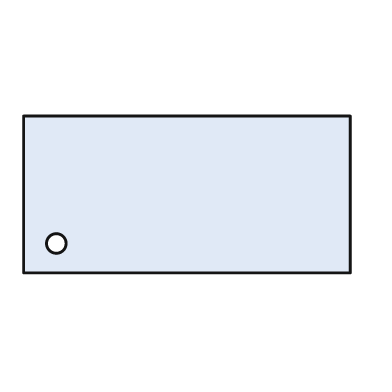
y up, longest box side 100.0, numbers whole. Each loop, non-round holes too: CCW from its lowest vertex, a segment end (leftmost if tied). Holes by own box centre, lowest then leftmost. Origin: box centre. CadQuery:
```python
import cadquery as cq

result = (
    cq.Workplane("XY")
    .moveTo(-50.0, -24.0)
    .lineTo(50.0, -24.0)
    .lineTo(50.0, 24.0)
    .lineTo(-50.0, 24.0)
    .close()
    .moveTo(-40.0, -15.0)
    .circle(3.0)
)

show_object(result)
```